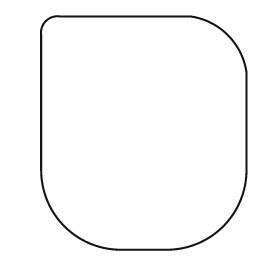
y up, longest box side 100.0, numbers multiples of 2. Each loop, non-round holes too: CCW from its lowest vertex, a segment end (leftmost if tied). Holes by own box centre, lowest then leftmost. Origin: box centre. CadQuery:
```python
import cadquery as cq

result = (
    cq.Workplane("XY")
    .moveTo(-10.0, -50.0)
    .lineTo(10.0, -50.0)
    .threePointArc((34.0, -40.0), (44.0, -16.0))
    .lineTo(44.0, 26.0)
    .threePointArc((36.0, 42.0), (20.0, 50.0))
    .lineTo(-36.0, 50.0)
    .threePointArc((-42.0, 48.0), (-44.0, 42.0))
    .lineTo(-44.0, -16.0)
    .threePointArc((-34.0, -40.0), (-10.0, -50.0))
    .close()
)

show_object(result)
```